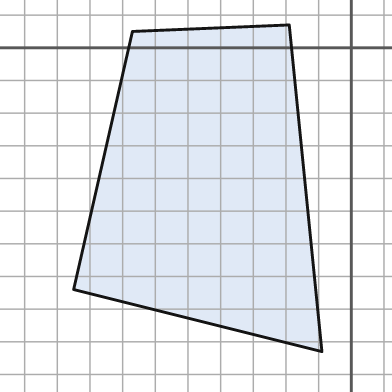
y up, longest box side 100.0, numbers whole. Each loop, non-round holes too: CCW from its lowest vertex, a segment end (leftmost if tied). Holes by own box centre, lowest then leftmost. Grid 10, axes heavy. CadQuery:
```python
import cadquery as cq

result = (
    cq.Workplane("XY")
    .moveTo(-9.0, -93.0)
    .lineTo(-19.0, 7.0)
    .lineTo(-67.0, 5.0)
    .lineTo(-85.0, -74.0)
    .close()
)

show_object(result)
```